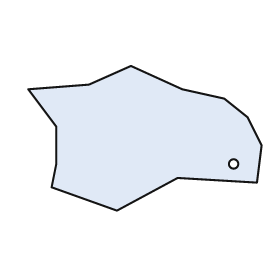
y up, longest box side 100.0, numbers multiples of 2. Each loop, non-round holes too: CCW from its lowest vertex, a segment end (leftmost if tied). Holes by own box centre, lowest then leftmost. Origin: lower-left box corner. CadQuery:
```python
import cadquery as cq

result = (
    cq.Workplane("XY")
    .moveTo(38.0, 0.0)
    .lineTo(64.0, 14.0)
    .lineTo(98.0, 12.0)
    .lineTo(100.0, 28.0)
    .lineTo(94.0, 40.0)
    .lineTo(84.0, 48.0)
    .lineTo(66.0, 52.0)
    .lineTo(44.0, 62.0)
    .lineTo(26.0, 54.0)
    .lineTo(0.0, 52.0)
    .lineTo(12.0, 36.0)
    .lineTo(12.0, 20.0)
    .lineTo(10.0, 10.0)
    .close()
    .moveTo(88.0, 20.0)
    .circle(2.0)
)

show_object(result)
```